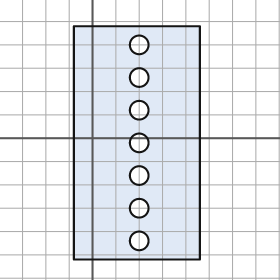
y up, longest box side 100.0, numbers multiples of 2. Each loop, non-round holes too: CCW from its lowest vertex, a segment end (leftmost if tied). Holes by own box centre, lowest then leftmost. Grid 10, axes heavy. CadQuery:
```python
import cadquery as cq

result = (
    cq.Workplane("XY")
    .moveTo(-8.0, -52.0)
    .lineTo(46.0, -52.0)
    .lineTo(46.0, 48.0)
    .lineTo(-8.0, 48.0)
    .close()
    .moveTo(20.0, -44.0)
    .circle(4.0)
    .moveTo(20.0, -30.0)
    .circle(4.0)
    .moveTo(20.0, -16.0)
    .circle(4.0)
    .moveTo(20.0, -2.0)
    .circle(4.0)
    .moveTo(20.0, 12.0)
    .circle(4.0)
    .moveTo(20.0, 26.0)
    .circle(4.0)
    .moveTo(20.0, 40.0)
    .circle(4.0)
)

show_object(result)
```